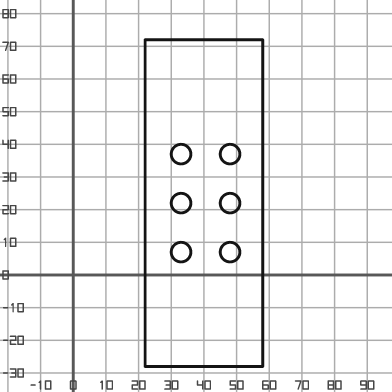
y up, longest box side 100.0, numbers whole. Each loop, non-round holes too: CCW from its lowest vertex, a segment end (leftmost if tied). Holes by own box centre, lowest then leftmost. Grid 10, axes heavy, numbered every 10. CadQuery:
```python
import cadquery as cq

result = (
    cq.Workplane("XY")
    .moveTo(22.0, -28.0)
    .lineTo(58.0, -28.0)
    .lineTo(58.0, 72.0)
    .lineTo(22.0, 72.0)
    .close()
    .moveTo(33.0, 7.0)
    .circle(3.0)
    .moveTo(48.0, 7.0)
    .circle(3.0)
    .moveTo(33.0, 22.0)
    .circle(3.0)
    .moveTo(48.0, 22.0)
    .circle(3.0)
    .moveTo(33.0, 37.0)
    .circle(3.0)
    .moveTo(48.0, 37.0)
    .circle(3.0)
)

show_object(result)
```